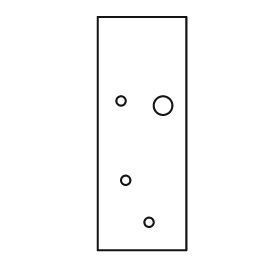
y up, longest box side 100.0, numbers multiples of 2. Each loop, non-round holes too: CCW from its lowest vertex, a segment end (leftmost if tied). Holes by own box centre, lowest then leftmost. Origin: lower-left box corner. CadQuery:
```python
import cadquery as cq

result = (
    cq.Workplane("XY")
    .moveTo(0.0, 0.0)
    .lineTo(38.0, 0.0)
    .lineTo(38.0, 100.0)
    .lineTo(0.0, 100.0)
    .close()
    .moveTo(22.0, 12.0)
    .circle(2.0)
    .moveTo(12.0, 30.0)
    .circle(2.0)
    .moveTo(28.0, 62.0)
    .circle(4.0)
    .moveTo(10.0, 64.0)
    .circle(2.0)
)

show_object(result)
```